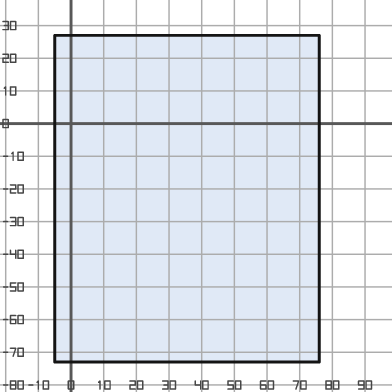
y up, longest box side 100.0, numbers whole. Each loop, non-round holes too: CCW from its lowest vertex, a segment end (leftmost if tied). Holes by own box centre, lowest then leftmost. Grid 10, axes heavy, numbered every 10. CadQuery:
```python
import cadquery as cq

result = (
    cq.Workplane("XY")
    .moveTo(-5.0, -73.0)
    .lineTo(76.0, -73.0)
    .lineTo(76.0, 27.0)
    .lineTo(-5.0, 27.0)
    .close()
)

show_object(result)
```